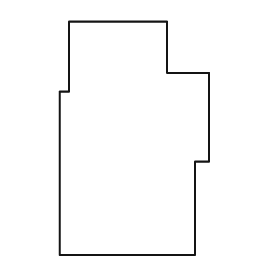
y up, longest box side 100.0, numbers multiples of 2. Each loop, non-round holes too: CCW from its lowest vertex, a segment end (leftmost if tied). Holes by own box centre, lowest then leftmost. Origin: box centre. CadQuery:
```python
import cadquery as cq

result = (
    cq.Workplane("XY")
    .moveTo(-32.0, -50.0)
    .lineTo(26.0, -50.0)
    .lineTo(26.0, -10.0)
    .lineTo(32.0, -10.0)
    .lineTo(32.0, 28.0)
    .lineTo(14.0, 28.0)
    .lineTo(14.0, 50.0)
    .lineTo(-28.0, 50.0)
    .lineTo(-28.0, 20.0)
    .lineTo(-32.0, 20.0)
    .close()
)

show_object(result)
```